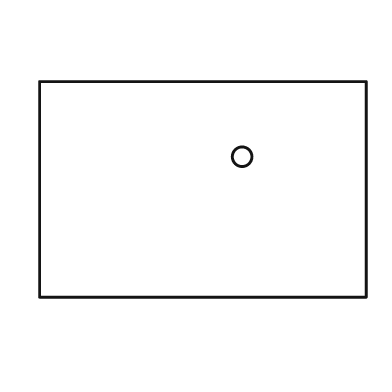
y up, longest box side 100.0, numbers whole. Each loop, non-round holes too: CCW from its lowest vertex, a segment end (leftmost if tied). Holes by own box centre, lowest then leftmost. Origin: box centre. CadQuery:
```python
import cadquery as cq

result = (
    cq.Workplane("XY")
    .moveTo(-50.0, -33.0)
    .lineTo(50.0, -33.0)
    .lineTo(50.0, 33.0)
    .lineTo(-50.0, 33.0)
    .close()
    .moveTo(12.0, 10.0)
    .circle(3.0)
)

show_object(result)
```